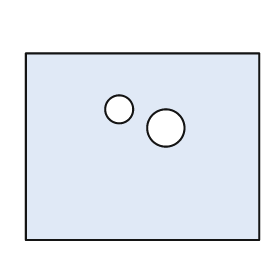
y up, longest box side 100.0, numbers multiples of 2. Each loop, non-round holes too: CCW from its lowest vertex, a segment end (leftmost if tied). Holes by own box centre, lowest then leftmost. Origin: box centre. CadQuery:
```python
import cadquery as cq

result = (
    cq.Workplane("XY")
    .moveTo(-50.0, -40.0)
    .lineTo(50.0, -40.0)
    .lineTo(50.0, 40.0)
    .lineTo(-50.0, 40.0)
    .close()
    .moveTo(10.0, 8.0)
    .circle(8.0)
    .moveTo(-10.0, 16.0)
    .circle(6.0)
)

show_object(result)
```